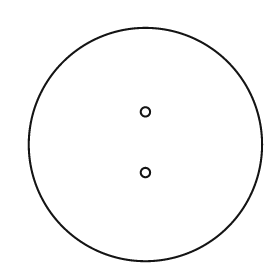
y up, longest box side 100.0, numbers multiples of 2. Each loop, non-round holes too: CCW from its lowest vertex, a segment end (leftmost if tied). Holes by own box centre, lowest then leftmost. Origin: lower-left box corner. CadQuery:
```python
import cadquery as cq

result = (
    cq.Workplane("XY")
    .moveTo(50.0, 50.0)
    .circle(50.0)
    .moveTo(50.0, 38.0)
    .circle(2.0)
    .moveTo(50.0, 64.0)
    .circle(2.0)
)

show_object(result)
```